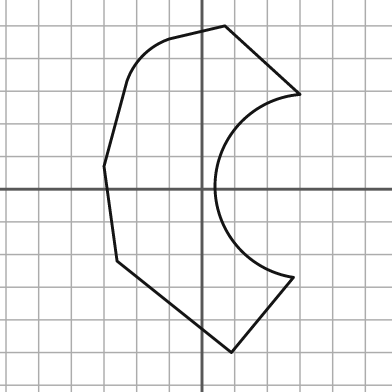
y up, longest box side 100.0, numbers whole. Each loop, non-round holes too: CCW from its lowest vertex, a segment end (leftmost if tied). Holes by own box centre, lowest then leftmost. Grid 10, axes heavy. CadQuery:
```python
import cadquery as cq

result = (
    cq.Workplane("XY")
    .moveTo(9.0, -50.0)
    .lineTo(28.0, -27.0)
    .threePointArc((4.0, 2.0), (30.0, 29.0))
    .lineTo(7.0, 50.0)
    .lineTo(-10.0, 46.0)
    .threePointArc((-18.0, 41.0), (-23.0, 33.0))
    .lineTo(-30.0, 7.0)
    .lineTo(-26.0, -22.0)
    .close()
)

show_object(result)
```